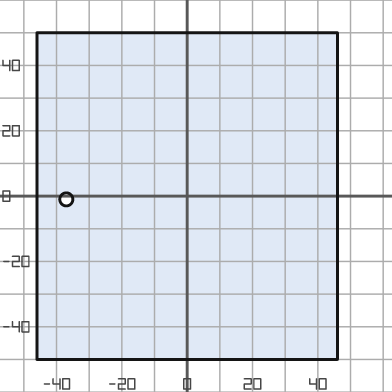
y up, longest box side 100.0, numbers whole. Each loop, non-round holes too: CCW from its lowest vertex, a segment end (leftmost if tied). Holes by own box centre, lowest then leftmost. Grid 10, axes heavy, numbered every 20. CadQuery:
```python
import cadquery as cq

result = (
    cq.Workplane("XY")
    .moveTo(-46.0, -50.0)
    .lineTo(46.0, -50.0)
    .lineTo(46.0, 50.0)
    .lineTo(-46.0, 50.0)
    .close()
    .moveTo(-37.0, -1.0)
    .circle(2.0)
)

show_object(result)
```